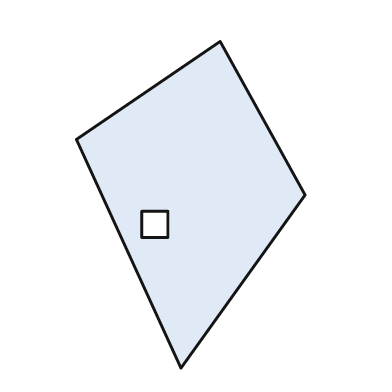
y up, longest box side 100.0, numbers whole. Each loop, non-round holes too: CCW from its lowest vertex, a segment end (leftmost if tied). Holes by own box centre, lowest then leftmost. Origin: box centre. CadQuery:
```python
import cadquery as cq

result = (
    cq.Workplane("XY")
    .moveTo(-3.0, -50.0)
    .lineTo(35.0, 3.0)
    .lineTo(9.0, 50.0)
    .lineTo(-35.0, 20.0)
    .close()
    .moveTo(-15.0, -10.0)
    .lineTo(-7.0, -10.0)
    .lineTo(-7.0, -2.0)
    .lineTo(-15.0, -2.0)
    .close()
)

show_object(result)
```